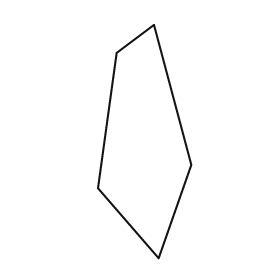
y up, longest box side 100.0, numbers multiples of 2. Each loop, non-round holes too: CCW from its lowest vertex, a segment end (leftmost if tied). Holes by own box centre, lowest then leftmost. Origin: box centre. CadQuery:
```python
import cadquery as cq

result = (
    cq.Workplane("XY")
    .moveTo(6.0, -50.0)
    .lineTo(20.0, -10.0)
    .lineTo(4.0, 50.0)
    .lineTo(-12.0, 38.0)
    .lineTo(-20.0, -20.0)
    .close()
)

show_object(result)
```